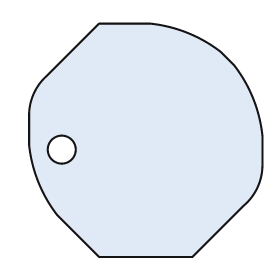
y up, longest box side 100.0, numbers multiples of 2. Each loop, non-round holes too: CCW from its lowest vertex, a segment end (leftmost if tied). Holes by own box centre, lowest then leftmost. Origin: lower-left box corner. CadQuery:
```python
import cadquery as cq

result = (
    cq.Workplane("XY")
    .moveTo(30.0, 0.0)
    .lineTo(70.0, 0.0)
    .lineTo(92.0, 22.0)
    .threePointArc((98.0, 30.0), (100.0, 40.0))
    .lineTo(100.0, 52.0)
    .threePointArc((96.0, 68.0), (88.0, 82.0))
    .lineTo(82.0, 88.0)
    .threePointArc((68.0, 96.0), (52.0, 100.0))
    .lineTo(30.0, 100.0)
    .lineTo(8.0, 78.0)
    .threePointArc((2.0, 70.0), (0.0, 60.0))
    .lineTo(0.0, 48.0)
    .threePointArc((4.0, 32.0), (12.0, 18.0))
    .close()
    .moveTo(14.0, 46.0)
    .circle(6.0)
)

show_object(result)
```